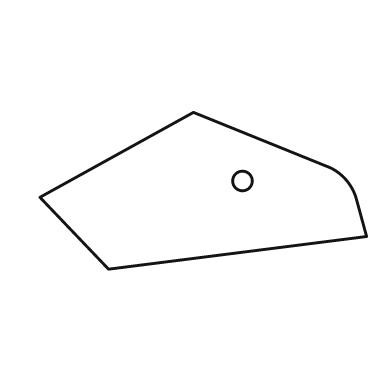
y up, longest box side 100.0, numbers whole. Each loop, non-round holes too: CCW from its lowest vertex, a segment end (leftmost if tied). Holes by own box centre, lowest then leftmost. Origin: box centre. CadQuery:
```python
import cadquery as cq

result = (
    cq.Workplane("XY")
    .moveTo(-29.0, -24.0)
    .lineTo(50.0, -14.0)
    .lineTo(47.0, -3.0)
    .threePointArc((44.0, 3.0), (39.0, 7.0))
    .lineTo(-3.0, 24.0)
    .lineTo(-50.0, -2.0)
    .close()
    .moveTo(12.0, 3.0)
    .circle(3.0)
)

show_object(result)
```